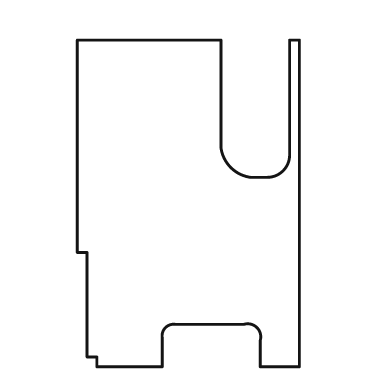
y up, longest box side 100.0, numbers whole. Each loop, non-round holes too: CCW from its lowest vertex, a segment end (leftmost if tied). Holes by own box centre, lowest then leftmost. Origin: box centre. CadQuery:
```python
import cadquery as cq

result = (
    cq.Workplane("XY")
    .moveTo(-28.0, -50.0)
    .lineTo(-8.0, -50.0)
    .lineTo(-8.0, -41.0)
    .threePointArc((-7.0, -38.0), (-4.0, -37.0))
    .lineTo(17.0, -37.0)
    .threePointArc((21.0, -38.0), (22.0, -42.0))
    .lineTo(22.0, -50.0)
    .lineTo(34.0, -50.0)
    .lineTo(34.0, 50.0)
    .lineTo(31.0, 50.0)
    .lineTo(31.0, 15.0)
    .threePointArc((29.0, 10.0), (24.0, 8.0))
    .lineTo(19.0, 8.0)
    .threePointArc((13.0, 11.0), (10.0, 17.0))
    .lineTo(10.0, 50.0)
    .lineTo(-34.0, 50.0)
    .lineTo(-34.0, -15.0)
    .lineTo(-31.0, -15.0)
    .lineTo(-31.0, -47.0)
    .lineTo(-28.0, -47.0)
    .close()
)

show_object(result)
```